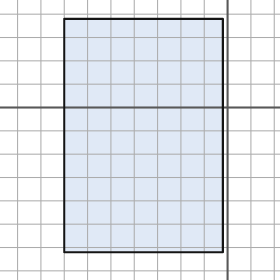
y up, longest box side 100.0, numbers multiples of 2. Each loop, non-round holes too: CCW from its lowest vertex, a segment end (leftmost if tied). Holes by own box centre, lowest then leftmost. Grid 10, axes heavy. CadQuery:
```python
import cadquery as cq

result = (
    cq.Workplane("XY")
    .moveTo(-70.0, -62.0)
    .lineTo(-2.0, -62.0)
    .lineTo(-2.0, 38.0)
    .lineTo(-70.0, 38.0)
    .close()
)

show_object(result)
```